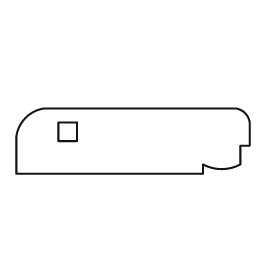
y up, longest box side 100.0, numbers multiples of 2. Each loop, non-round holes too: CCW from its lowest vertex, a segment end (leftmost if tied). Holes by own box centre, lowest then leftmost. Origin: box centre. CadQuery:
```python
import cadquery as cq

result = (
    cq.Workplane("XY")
    .moveTo(-50.0, -14.0)
    .lineTo(30.0, -14.0)
    .lineTo(30.0, -10.0)
    .threePointArc((38.0, -12.0), (46.0, -10.0))
    .lineTo(46.0, -2.0)
    .lineTo(50.0, -2.0)
    .lineTo(50.0, 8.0)
    .threePointArc((48.0, 12.0), (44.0, 14.0))
    .lineTo(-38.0, 14.0)
    .threePointArc((-46.0, 10.0), (-50.0, 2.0))
    .close()
    .moveTo(-32.0, 0.0)
    .lineTo(-24.0, 0.0)
    .lineTo(-24.0, 8.0)
    .lineTo(-32.0, 8.0)
    .close()
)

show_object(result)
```